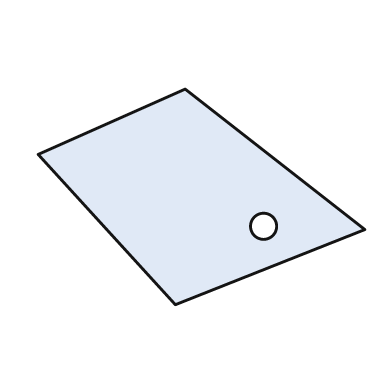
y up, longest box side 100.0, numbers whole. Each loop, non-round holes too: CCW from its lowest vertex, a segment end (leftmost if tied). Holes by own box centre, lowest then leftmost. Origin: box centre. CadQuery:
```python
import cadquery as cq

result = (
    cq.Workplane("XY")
    .moveTo(-8.0, -33.0)
    .lineTo(50.0, -10.0)
    .lineTo(-5.0, 33.0)
    .lineTo(-50.0, 13.0)
    .close()
    .moveTo(19.0, -9.0)
    .circle(4.0)
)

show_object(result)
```